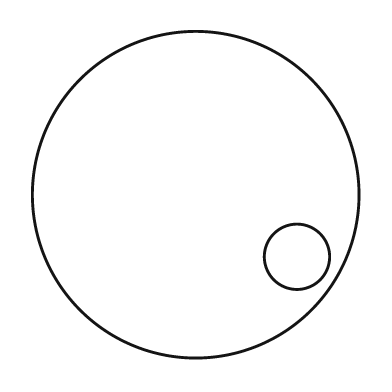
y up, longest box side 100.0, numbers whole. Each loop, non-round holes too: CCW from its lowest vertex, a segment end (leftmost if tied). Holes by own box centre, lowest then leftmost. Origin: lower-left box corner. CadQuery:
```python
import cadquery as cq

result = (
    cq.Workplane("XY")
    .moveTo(50.0, 50.0)
    .circle(50.0)
    .moveTo(81.0, 31.0)
    .circle(10.0)
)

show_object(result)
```